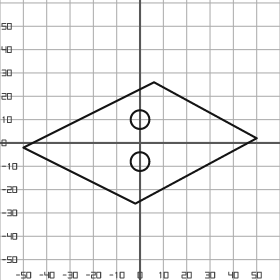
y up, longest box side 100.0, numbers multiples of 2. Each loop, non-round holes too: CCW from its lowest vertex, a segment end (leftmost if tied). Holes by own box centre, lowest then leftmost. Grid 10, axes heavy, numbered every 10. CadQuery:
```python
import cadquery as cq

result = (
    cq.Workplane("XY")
    .moveTo(-2.0, -26.0)
    .lineTo(50.0, 2.0)
    .lineTo(6.0, 26.0)
    .lineTo(-50.0, -2.0)
    .close()
    .moveTo(0.0, -8.0)
    .circle(4.0)
    .moveTo(0.0, 10.0)
    .circle(4.0)
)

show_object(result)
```